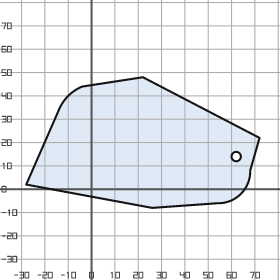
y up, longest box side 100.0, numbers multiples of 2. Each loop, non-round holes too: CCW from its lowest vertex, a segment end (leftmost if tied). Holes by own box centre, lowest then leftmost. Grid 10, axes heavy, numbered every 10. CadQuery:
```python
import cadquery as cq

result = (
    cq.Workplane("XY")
    .moveTo(26.0, -8.0)
    .lineTo(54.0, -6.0)
    .threePointArc((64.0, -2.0), (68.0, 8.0))
    .lineTo(72.0, 22.0)
    .lineTo(22.0, 48.0)
    .lineTo(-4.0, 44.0)
    .threePointArc((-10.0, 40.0), (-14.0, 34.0))
    .lineTo(-28.0, 2.0)
    .close()
    .moveTo(62.0, 14.0)
    .circle(2.0)
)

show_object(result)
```